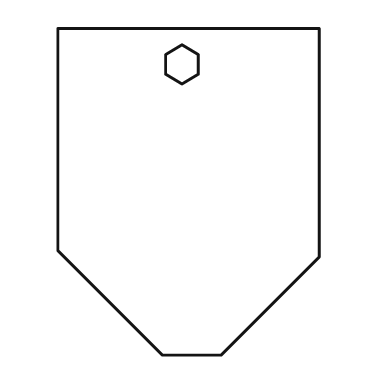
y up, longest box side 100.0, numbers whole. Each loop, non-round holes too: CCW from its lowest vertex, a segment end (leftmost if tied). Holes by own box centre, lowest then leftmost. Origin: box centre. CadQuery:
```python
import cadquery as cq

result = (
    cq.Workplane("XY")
    .moveTo(-8.0, -50.0)
    .lineTo(10.0, -50.0)
    .lineTo(40.0, -20.0)
    .lineTo(40.0, 50.0)
    .lineTo(-40.0, 50.0)
    .lineTo(-40.0, -18.0)
    .close()
    .moveTo(-2.0, 33.0)
    .lineTo(3.0, 36.0)
    .lineTo(3.0, 42.0)
    .lineTo(-2.0, 45.0)
    .lineTo(-7.0, 42.0)
    .lineTo(-7.0, 36.0)
    .close()
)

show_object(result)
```